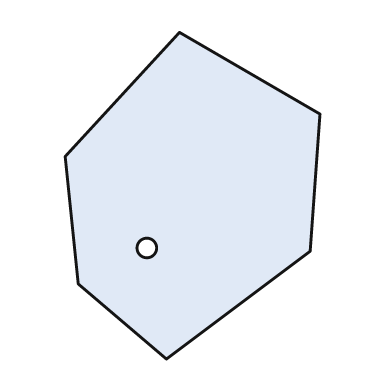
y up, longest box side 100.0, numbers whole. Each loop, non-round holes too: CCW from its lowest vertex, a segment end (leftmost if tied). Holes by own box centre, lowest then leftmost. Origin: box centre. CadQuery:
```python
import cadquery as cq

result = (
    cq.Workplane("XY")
    .moveTo(-8.0, -50.0)
    .lineTo(36.0, -17.0)
    .lineTo(39.0, 25.0)
    .lineTo(-4.0, 50.0)
    .lineTo(-39.0, 12.0)
    .lineTo(-35.0, -27.0)
    .close()
    .moveTo(-14.0, -16.0)
    .circle(3.0)
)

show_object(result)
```